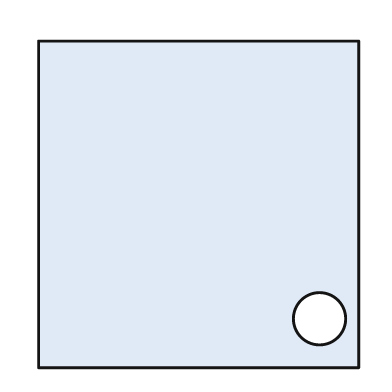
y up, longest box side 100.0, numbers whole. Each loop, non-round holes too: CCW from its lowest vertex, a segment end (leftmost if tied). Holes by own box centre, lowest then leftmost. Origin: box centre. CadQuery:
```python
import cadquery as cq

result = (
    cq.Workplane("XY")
    .moveTo(-49.0, -50.0)
    .lineTo(49.0, -50.0)
    .lineTo(49.0, 50.0)
    .lineTo(-49.0, 50.0)
    .close()
    .moveTo(37.0, -35.0)
    .circle(8.0)
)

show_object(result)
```